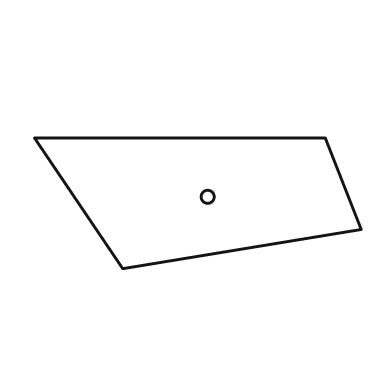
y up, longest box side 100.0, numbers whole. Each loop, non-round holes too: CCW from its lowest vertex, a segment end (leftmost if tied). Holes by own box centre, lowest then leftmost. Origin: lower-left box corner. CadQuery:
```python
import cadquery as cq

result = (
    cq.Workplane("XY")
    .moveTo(27.0, 0.0)
    .lineTo(100.0, 12.0)
    .lineTo(89.0, 40.0)
    .lineTo(0.0, 40.0)
    .close()
    .moveTo(53.0, 22.0)
    .circle(2.0)
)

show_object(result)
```